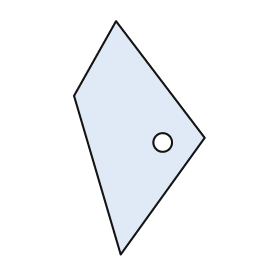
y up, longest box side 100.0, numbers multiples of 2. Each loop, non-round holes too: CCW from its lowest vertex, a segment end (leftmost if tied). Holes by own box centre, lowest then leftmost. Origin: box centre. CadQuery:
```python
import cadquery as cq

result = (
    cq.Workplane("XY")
    .moveTo(-8.0, -50.0)
    .lineTo(28.0, 0.0)
    .lineTo(-10.0, 50.0)
    .lineTo(-28.0, 18.0)
    .close()
    .moveTo(10.0, -2.0)
    .circle(4.0)
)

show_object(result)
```